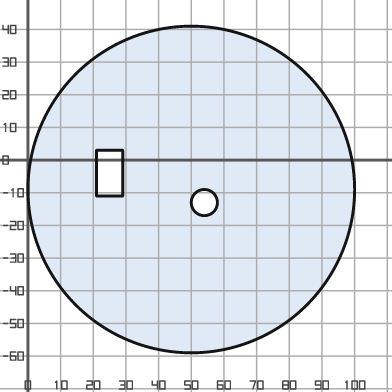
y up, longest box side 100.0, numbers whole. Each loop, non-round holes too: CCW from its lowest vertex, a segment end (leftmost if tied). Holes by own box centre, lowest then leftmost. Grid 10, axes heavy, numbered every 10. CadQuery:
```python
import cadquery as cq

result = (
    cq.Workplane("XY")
    .moveTo(50.0, -9.0)
    .circle(50.0)
    .moveTo(54.0, -13.0)
    .circle(4.0)
    .moveTo(21.0, -11.0)
    .lineTo(29.0, -11.0)
    .lineTo(29.0, 3.0)
    .lineTo(21.0, 3.0)
    .close()
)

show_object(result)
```